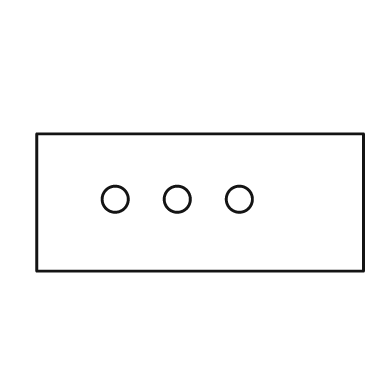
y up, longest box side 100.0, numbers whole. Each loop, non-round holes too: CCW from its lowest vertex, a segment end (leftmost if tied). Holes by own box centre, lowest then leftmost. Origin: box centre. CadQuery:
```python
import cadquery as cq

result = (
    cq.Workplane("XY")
    .moveTo(-50.0, -21.0)
    .lineTo(50.0, -21.0)
    .lineTo(50.0, 21.0)
    .lineTo(-50.0, 21.0)
    .close()
    .moveTo(-26.0, 1.0)
    .circle(4.0)
    .moveTo(-7.0, 1.0)
    .circle(4.0)
    .moveTo(12.0, 1.0)
    .circle(4.0)
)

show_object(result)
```